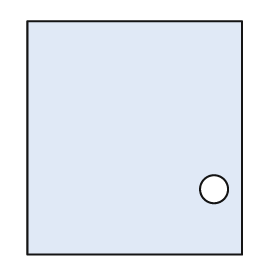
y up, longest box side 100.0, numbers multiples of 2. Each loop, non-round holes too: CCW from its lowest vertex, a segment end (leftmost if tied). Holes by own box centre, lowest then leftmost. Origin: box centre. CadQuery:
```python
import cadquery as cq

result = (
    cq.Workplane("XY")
    .moveTo(-46.0, -50.0)
    .lineTo(46.0, -50.0)
    .lineTo(46.0, 50.0)
    .lineTo(-46.0, 50.0)
    .close()
    .moveTo(34.0, -22.0)
    .circle(6.0)
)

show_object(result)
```